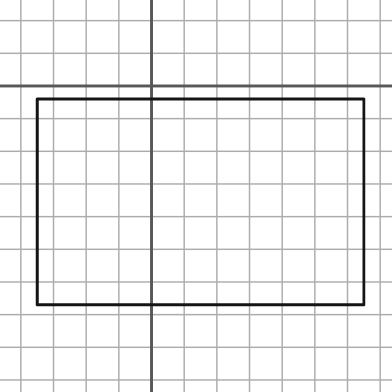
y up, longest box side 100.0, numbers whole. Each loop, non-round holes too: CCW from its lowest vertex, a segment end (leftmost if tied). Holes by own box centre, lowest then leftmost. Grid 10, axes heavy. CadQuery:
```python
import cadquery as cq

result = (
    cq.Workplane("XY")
    .moveTo(-35.0, -67.0)
    .lineTo(65.0, -67.0)
    .lineTo(65.0, -4.0)
    .lineTo(-35.0, -4.0)
    .close()
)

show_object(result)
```